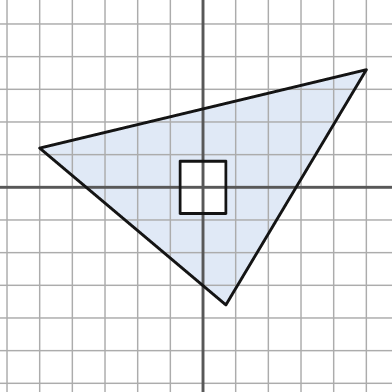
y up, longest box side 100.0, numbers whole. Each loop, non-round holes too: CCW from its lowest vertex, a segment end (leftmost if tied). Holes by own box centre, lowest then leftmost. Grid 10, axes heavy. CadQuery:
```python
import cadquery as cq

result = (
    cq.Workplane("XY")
    .moveTo(7.0, -36.0)
    .lineTo(50.0, 36.0)
    .lineTo(-50.0, 12.0)
    .close()
    .moveTo(-7.0, -8.0)
    .lineTo(7.0, -8.0)
    .lineTo(7.0, 8.0)
    .lineTo(-7.0, 8.0)
    .close()
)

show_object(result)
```